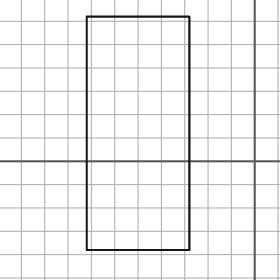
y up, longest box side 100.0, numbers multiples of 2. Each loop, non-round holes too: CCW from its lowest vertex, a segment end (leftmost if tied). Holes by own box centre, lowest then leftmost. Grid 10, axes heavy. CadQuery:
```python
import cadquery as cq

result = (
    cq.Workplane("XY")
    .moveTo(-72.0, -38.0)
    .lineTo(-28.0, -38.0)
    .lineTo(-28.0, 62.0)
    .lineTo(-72.0, 62.0)
    .close()
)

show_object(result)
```